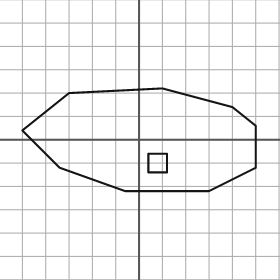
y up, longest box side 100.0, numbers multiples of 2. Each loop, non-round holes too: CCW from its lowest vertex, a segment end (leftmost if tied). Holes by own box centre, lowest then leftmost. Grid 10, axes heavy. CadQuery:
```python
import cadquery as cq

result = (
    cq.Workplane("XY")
    .moveTo(-6.0, -22.0)
    .lineTo(30.0, -22.0)
    .lineTo(50.0, -12.0)
    .lineTo(50.0, 6.0)
    .lineTo(40.0, 14.0)
    .lineTo(10.0, 22.0)
    .lineTo(-30.0, 20.0)
    .lineTo(-50.0, 4.0)
    .lineTo(-34.0, -12.0)
    .close()
    .moveTo(4.0, -14.0)
    .lineTo(12.0, -14.0)
    .lineTo(12.0, -6.0)
    .lineTo(4.0, -6.0)
    .close()
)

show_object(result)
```